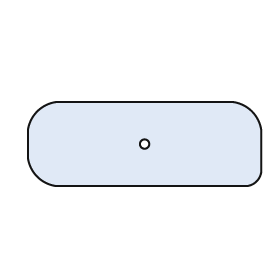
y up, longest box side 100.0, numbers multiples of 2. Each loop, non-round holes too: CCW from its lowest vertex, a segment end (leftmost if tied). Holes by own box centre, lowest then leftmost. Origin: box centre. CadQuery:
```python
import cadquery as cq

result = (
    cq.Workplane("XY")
    .moveTo(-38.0, -18.0)
    .lineTo(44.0, -18.0)
    .threePointArc((48.0, -16.0), (50.0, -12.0))
    .lineTo(50.0, 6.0)
    .threePointArc((46.0, 14.0), (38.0, 18.0))
    .lineTo(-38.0, 18.0)
    .threePointArc((-46.0, 14.0), (-50.0, 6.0))
    .lineTo(-50.0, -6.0)
    .threePointArc((-46.0, -14.0), (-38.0, -18.0))
    .close()
    .moveTo(0.0, 0.0)
    .circle(2.0)
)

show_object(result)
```